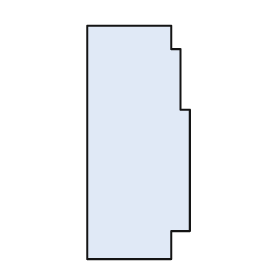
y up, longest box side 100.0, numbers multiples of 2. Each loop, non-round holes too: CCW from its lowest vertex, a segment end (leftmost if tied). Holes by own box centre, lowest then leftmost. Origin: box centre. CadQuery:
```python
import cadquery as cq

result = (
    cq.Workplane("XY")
    .moveTo(-22.0, -50.0)
    .lineTo(14.0, -50.0)
    .lineTo(14.0, -38.0)
    .lineTo(22.0, -38.0)
    .lineTo(22.0, 14.0)
    .lineTo(18.0, 14.0)
    .lineTo(18.0, 40.0)
    .lineTo(14.0, 40.0)
    .lineTo(14.0, 50.0)
    .lineTo(-22.0, 50.0)
    .close()
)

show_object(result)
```